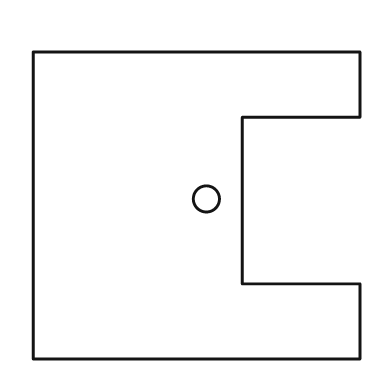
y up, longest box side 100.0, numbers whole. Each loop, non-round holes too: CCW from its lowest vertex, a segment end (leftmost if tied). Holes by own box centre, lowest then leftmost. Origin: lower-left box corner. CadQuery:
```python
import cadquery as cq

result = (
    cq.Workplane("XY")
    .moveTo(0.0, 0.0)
    .lineTo(100.0, 0.0)
    .lineTo(100.0, 23.0)
    .lineTo(64.0, 23.0)
    .lineTo(64.0, 74.0)
    .lineTo(100.0, 74.0)
    .lineTo(100.0, 94.0)
    .lineTo(0.0, 94.0)
    .close()
    .moveTo(53.0, 49.0)
    .circle(4.0)
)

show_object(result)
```